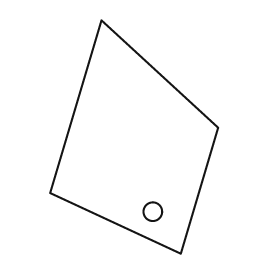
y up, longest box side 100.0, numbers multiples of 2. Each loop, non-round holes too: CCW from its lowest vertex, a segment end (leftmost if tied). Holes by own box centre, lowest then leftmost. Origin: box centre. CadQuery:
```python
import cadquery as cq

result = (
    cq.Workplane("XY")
    .moveTo(20.0, -50.0)
    .lineTo(36.0, 4.0)
    .lineTo(-14.0, 50.0)
    .lineTo(-36.0, -24.0)
    .close()
    .moveTo(8.0, -32.0)
    .circle(4.0)
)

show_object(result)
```